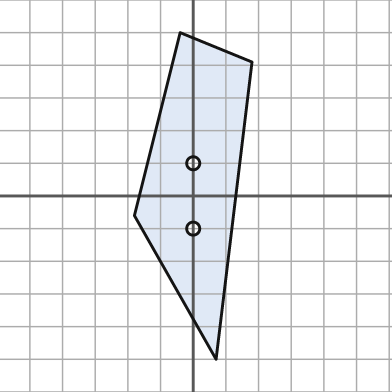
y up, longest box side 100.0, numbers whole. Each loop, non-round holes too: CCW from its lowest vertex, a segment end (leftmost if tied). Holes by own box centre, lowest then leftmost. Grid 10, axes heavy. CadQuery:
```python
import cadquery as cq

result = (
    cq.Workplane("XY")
    .moveTo(7.0, -50.0)
    .lineTo(18.0, 41.0)
    .lineTo(-4.0, 50.0)
    .lineTo(-18.0, -6.0)
    .close()
    .moveTo(0.0, -10.0)
    .circle(2.0)
    .moveTo(0.0, 10.0)
    .circle(2.0)
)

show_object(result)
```